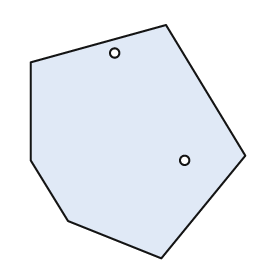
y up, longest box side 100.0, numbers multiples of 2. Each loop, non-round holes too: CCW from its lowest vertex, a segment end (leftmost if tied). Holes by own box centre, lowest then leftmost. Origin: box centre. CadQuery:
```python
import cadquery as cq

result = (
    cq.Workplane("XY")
    .moveTo(10.0, -50.0)
    .lineTo(46.0, -6.0)
    .lineTo(12.0, 50.0)
    .lineTo(-46.0, 34.0)
    .lineTo(-46.0, -8.0)
    .lineTo(-30.0, -34.0)
    .close()
    .moveTo(20.0, -8.0)
    .circle(2.0)
    .moveTo(-10.0, 38.0)
    .circle(2.0)
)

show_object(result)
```